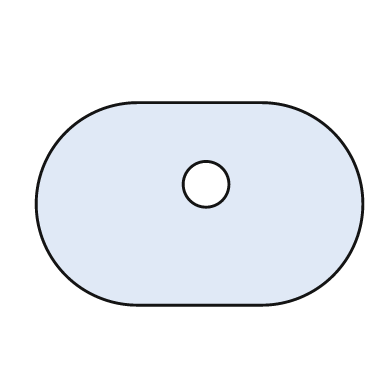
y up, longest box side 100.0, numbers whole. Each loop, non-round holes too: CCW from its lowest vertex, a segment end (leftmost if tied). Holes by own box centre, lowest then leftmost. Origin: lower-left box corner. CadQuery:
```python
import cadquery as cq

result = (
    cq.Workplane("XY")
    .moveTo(31.0, 0.0)
    .lineTo(69.0, 0.0)
    .threePointArc((100.0, 31.0), (69.0, 62.0))
    .lineTo(31.0, 62.0)
    .threePointArc((0.0, 31.0), (31.0, 0.0))
    .close()
    .moveTo(52.0, 37.0)
    .circle(7.0)
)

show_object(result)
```